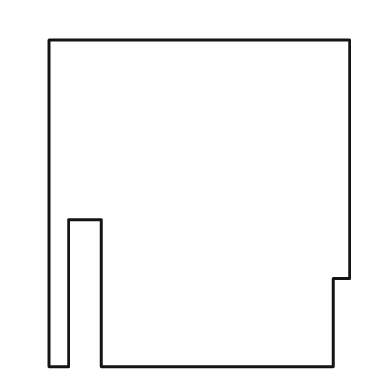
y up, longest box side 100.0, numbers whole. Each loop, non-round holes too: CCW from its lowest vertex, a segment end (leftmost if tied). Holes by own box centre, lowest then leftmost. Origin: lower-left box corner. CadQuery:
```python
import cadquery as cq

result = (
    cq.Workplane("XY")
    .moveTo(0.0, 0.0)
    .lineTo(6.0, 0.0)
    .lineTo(6.0, 45.0)
    .lineTo(16.0, 45.0)
    .lineTo(16.0, 0.0)
    .lineTo(87.0, 0.0)
    .lineTo(87.0, 27.0)
    .lineTo(92.0, 27.0)
    .lineTo(92.0, 100.0)
    .lineTo(0.0, 100.0)
    .close()
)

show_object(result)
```